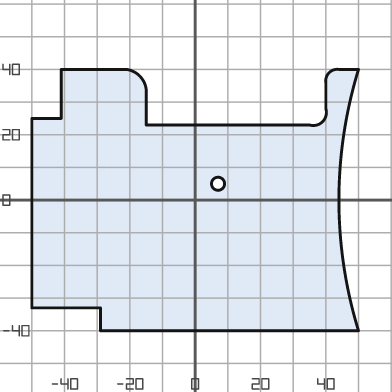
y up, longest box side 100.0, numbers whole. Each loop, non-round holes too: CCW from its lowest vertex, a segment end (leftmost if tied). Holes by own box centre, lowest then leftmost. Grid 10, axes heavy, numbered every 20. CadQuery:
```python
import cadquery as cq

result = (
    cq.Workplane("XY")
    .moveTo(-29.0, -40.0)
    .lineTo(50.0, -40.0)
    .threePointArc((44.0, 0.0), (50.0, 40.0))
    .lineTo(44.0, 40.0)
    .threePointArc((41.0, 39.0), (40.0, 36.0))
    .lineTo(40.0, 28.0)
    .threePointArc((39.0, 24.0), (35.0, 23.0))
    .lineTo(-15.0, 23.0)
    .lineTo(-15.0, 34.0)
    .threePointArc((-17.0, 38.0), (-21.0, 40.0))
    .lineTo(-41.0, 40.0)
    .lineTo(-41.0, 25.0)
    .lineTo(-50.0, 25.0)
    .lineTo(-50.0, -33.0)
    .lineTo(-29.0, -33.0)
    .close()
    .moveTo(7.0, 5.0)
    .circle(2.0)
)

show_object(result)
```